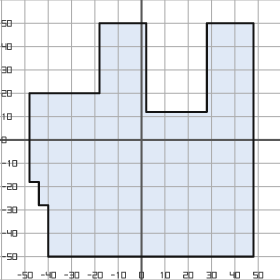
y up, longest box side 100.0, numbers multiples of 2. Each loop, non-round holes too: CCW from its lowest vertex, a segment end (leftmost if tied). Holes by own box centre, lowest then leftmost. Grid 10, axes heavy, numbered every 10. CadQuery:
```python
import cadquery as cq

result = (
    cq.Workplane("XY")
    .moveTo(-40.0, -50.0)
    .lineTo(48.0, -50.0)
    .lineTo(48.0, 50.0)
    .lineTo(28.0, 50.0)
    .lineTo(28.0, 12.0)
    .lineTo(2.0, 12.0)
    .lineTo(2.0, 50.0)
    .lineTo(-18.0, 50.0)
    .lineTo(-18.0, 20.0)
    .lineTo(-48.0, 20.0)
    .lineTo(-48.0, -18.0)
    .lineTo(-44.0, -18.0)
    .lineTo(-44.0, -28.0)
    .lineTo(-40.0, -28.0)
    .close()
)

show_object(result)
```